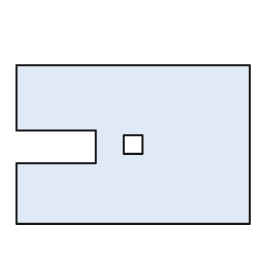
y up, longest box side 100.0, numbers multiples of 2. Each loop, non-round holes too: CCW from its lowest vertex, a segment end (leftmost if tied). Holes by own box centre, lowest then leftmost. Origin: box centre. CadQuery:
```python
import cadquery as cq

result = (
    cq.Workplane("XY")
    .moveTo(-50.0, -34.0)
    .lineTo(50.0, -34.0)
    .lineTo(50.0, 34.0)
    .lineTo(-50.0, 34.0)
    .lineTo(-50.0, 6.0)
    .lineTo(-16.0, 6.0)
    .lineTo(-16.0, -8.0)
    .lineTo(-50.0, -8.0)
    .close()
    .moveTo(-4.0, -4.0)
    .lineTo(4.0, -4.0)
    .lineTo(4.0, 4.0)
    .lineTo(-4.0, 4.0)
    .close()
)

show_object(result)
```